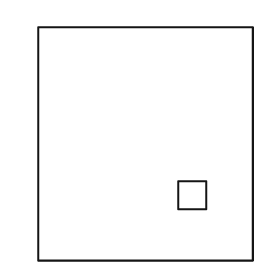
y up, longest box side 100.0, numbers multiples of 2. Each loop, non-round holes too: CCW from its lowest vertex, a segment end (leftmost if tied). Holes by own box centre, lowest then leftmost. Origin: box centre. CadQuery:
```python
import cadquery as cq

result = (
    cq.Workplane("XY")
    .moveTo(-46.0, -50.0)
    .lineTo(46.0, -50.0)
    .lineTo(46.0, 50.0)
    .lineTo(-46.0, 50.0)
    .close()
    .moveTo(14.0, -28.0)
    .lineTo(26.0, -28.0)
    .lineTo(26.0, -16.0)
    .lineTo(14.0, -16.0)
    .close()
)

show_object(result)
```